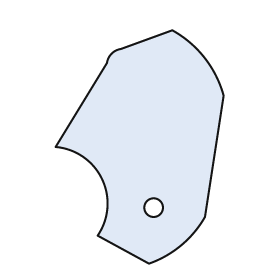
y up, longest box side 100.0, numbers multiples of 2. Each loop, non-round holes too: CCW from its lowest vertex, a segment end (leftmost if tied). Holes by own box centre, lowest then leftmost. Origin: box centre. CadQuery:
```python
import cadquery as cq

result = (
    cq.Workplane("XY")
    .moveTo(4.0, -50.0)
    .threePointArc((18.0, -42.0), (28.0, -30.0))
    .lineTo(36.0, 22.0)
    .threePointArc((28.0, 38.0), (14.0, 50.0))
    .lineTo(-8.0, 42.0)
    .threePointArc((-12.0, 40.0), (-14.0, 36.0))
    .lineTo(-36.0, 0.0)
    .threePointArc((-16.0, -14.0), (-18.0, -38.0))
    .close()
    .moveTo(6.0, -26.0)
    .circle(4.0)
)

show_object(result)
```